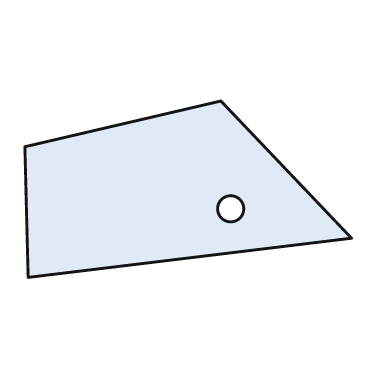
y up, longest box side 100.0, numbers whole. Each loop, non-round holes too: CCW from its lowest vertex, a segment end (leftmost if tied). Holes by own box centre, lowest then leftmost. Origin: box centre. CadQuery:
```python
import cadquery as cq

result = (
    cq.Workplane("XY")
    .moveTo(-49.0, -27.0)
    .lineTo(50.0, -15.0)
    .lineTo(10.0, 27.0)
    .lineTo(-50.0, 13.0)
    .close()
    .moveTo(13.0, -6.0)
    .circle(4.0)
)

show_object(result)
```